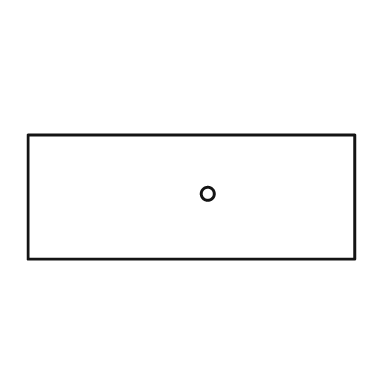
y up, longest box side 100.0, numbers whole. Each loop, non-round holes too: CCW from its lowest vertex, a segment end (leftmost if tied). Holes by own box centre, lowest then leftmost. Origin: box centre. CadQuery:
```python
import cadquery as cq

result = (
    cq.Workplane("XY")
    .moveTo(-50.0, -19.0)
    .lineTo(50.0, -19.0)
    .lineTo(50.0, 19.0)
    .lineTo(-50.0, 19.0)
    .close()
    .moveTo(5.0, 1.0)
    .circle(2.0)
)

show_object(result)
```